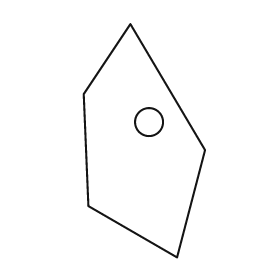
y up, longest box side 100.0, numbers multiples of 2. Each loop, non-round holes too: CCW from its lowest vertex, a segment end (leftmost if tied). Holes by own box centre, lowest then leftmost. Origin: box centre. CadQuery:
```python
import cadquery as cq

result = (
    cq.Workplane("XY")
    .moveTo(14.0, -50.0)
    .lineTo(26.0, -4.0)
    .lineTo(-6.0, 50.0)
    .lineTo(-26.0, 20.0)
    .lineTo(-24.0, -28.0)
    .close()
    .moveTo(2.0, 8.0)
    .circle(6.0)
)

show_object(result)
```